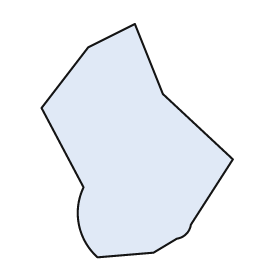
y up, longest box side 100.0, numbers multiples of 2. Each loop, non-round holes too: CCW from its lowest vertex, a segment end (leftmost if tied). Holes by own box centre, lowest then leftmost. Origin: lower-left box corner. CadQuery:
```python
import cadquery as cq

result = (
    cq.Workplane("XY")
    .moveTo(24.0, 0.0)
    .lineTo(48.0, 2.0)
    .lineTo(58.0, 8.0)
    .threePointArc((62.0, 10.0), (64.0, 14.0))
    .lineTo(82.0, 42.0)
    .lineTo(52.0, 70.0)
    .lineTo(40.0, 100.0)
    .lineTo(20.0, 90.0)
    .lineTo(0.0, 64.0)
    .lineTo(18.0, 30.0)
    .threePointArc((16.0, 14.0), (24.0, 0.0))
    .close()
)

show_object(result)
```